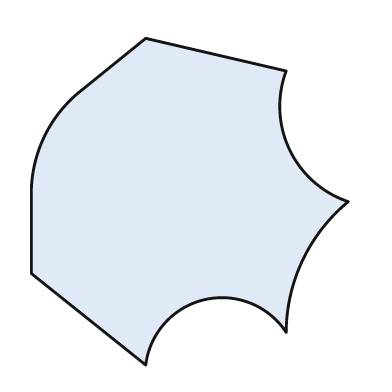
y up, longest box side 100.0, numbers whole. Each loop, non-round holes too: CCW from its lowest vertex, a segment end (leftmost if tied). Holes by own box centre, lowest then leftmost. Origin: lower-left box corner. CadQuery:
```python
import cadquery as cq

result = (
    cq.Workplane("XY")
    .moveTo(35.0, 0.0)
    .threePointArc((53.0, 20.0), (78.0, 10.0))
    .threePointArc((83.0, 32.0), (97.0, 50.0))
    .threePointArc((79.0, 66.0), (78.0, 90.0))
    .lineTo(35.0, 100.0)
    .lineTo(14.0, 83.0)
    .threePointArc((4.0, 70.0), (0.0, 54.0))
    .lineTo(0.0, 28.0)
    .close()
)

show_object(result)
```